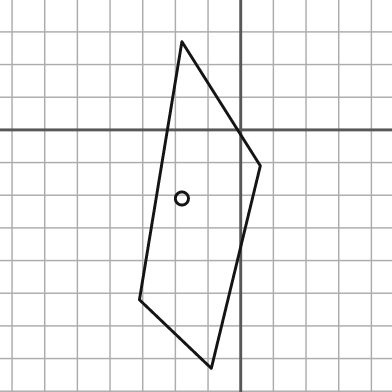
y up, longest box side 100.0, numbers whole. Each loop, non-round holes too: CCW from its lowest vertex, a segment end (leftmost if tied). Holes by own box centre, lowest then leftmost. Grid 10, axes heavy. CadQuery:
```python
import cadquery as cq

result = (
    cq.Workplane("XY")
    .moveTo(-9.0, -73.0)
    .lineTo(6.0, -11.0)
    .lineTo(-18.0, 27.0)
    .lineTo(-31.0, -52.0)
    .close()
    .moveTo(-18.0, -21.0)
    .circle(2.0)
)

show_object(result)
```